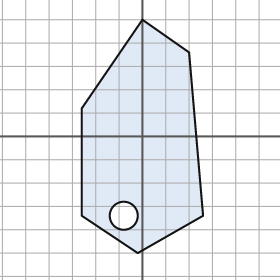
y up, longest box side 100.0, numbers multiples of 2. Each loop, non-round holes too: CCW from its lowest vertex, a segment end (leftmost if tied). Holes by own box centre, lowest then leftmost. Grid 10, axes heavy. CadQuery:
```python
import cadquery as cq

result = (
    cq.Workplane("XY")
    .moveTo(-2.0, -50.0)
    .lineTo(26.0, -34.0)
    .lineTo(20.0, 36.0)
    .lineTo(0.0, 50.0)
    .lineTo(-26.0, 12.0)
    .lineTo(-26.0, -34.0)
    .close()
    .moveTo(-8.0, -34.0)
    .circle(6.0)
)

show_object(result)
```